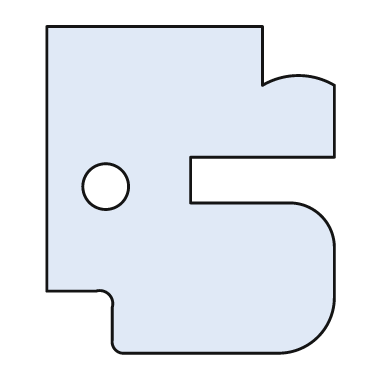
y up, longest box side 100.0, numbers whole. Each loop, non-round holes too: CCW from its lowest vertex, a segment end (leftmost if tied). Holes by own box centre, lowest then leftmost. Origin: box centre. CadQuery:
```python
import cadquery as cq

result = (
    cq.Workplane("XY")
    .moveTo(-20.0, -50.0)
    .lineTo(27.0, -50.0)
    .threePointArc((39.0, -45.0), (44.0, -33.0))
    .lineTo(44.0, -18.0)
    .threePointArc((40.0, -8.0), (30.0, -4.0))
    .lineTo(0.0, -4.0)
    .lineTo(0.0, 10.0)
    .lineTo(44.0, 10.0)
    .lineTo(44.0, 32.0)
    .threePointArc((33.0, 35.0), (22.0, 32.0))
    .lineTo(22.0, 50.0)
    .lineTo(-44.0, 50.0)
    .lineTo(-44.0, -31.0)
    .lineTo(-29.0, -31.0)
    .threePointArc((-25.0, -32.0), (-24.0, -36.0))
    .lineTo(-24.0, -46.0)
    .threePointArc((-23.0, -49.0), (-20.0, -50.0))
    .close()
    .moveTo(-26.0, 1.0)
    .circle(7.0)
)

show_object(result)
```